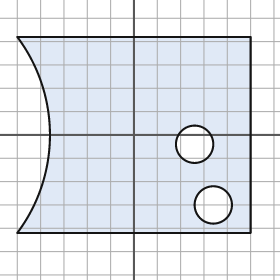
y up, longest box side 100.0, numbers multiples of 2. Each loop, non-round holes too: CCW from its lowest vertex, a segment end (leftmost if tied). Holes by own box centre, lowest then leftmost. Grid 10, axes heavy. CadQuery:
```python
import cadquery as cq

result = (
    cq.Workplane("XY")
    .moveTo(-50.0, -42.0)
    .lineTo(50.0, -42.0)
    .lineTo(50.0, 42.0)
    .lineTo(-50.0, 42.0)
    .threePointArc((-36.0, 0.0), (-50.0, -42.0))
    .close()
    .moveTo(34.0, -30.0)
    .circle(8.0)
    .moveTo(26.0, -4.0)
    .circle(8.0)
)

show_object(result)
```